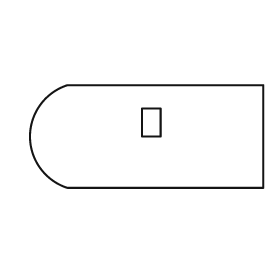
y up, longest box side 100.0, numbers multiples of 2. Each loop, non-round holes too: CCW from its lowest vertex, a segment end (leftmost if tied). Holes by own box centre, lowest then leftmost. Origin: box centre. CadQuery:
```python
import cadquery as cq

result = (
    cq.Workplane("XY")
    .moveTo(-34.0, -22.0)
    .lineTo(50.0, -22.0)
    .lineTo(50.0, 22.0)
    .lineTo(-34.0, 22.0)
    .threePointArc((-50.0, 0.0), (-34.0, -22.0))
    .close()
    .moveTo(-2.0, 0.0)
    .lineTo(6.0, 0.0)
    .lineTo(6.0, 12.0)
    .lineTo(-2.0, 12.0)
    .close()
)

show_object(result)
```